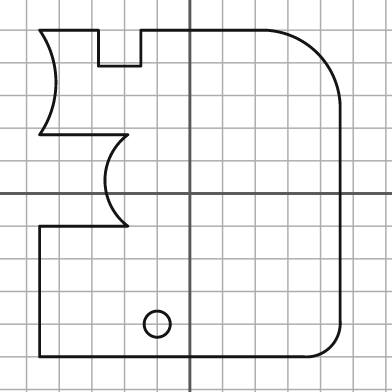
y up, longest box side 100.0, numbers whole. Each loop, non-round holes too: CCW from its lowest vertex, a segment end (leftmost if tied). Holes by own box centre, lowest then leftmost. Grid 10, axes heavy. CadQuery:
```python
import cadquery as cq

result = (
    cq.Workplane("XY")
    .moveTo(-46.0, -50.0)
    .lineTo(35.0, -50.0)
    .threePointArc((43.0, -47.0), (46.0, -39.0))
    .lineTo(46.0, 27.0)
    .threePointArc((39.0, 43.0), (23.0, 50.0))
    .lineTo(-15.0, 50.0)
    .lineTo(-15.0, 39.0)
    .lineTo(-28.0, 39.0)
    .lineTo(-28.0, 50.0)
    .lineTo(-46.0, 50.0)
    .threePointArc((-41.0, 34.0), (-46.0, 18.0))
    .lineTo(-19.0, 18.0)
    .threePointArc((-26.0, 4.0), (-19.0, -10.0))
    .lineTo(-46.0, -10.0)
    .close()
    .moveTo(-10.0, -40.0)
    .circle(4.0)
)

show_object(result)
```